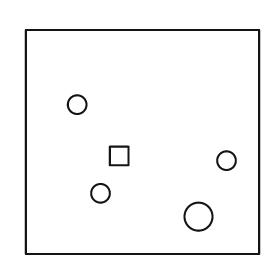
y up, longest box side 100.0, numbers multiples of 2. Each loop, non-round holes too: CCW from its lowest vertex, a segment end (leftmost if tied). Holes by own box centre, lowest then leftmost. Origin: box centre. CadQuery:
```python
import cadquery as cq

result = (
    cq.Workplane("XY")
    .moveTo(-50.0, -48.0)
    .lineTo(50.0, -48.0)
    .lineTo(50.0, 48.0)
    .lineTo(-50.0, 48.0)
    .close()
    .moveTo(24.0, -32.0)
    .circle(6.0)
    .moveTo(-18.0, -22.0)
    .circle(4.0)
    .moveTo(36.0, -8.0)
    .circle(4.0)
    .moveTo(-14.0, -10.0)
    .lineTo(-6.0, -10.0)
    .lineTo(-6.0, -2.0)
    .lineTo(-14.0, -2.0)
    .close()
    .moveTo(-28.0, 16.0)
    .circle(4.0)
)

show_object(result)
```